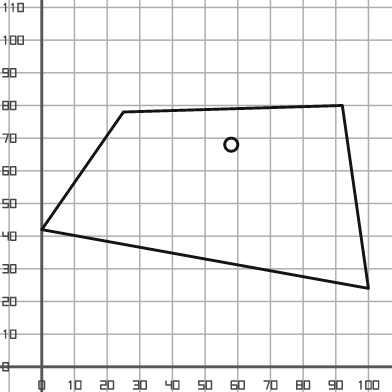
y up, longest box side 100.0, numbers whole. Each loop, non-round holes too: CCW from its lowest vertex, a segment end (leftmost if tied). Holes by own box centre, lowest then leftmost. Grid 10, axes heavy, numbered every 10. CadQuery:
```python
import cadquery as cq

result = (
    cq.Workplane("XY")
    .moveTo(100.0, 24.0)
    .lineTo(92.0, 80.0)
    .lineTo(25.0, 78.0)
    .lineTo(0.0, 42.0)
    .close()
    .moveTo(58.0, 68.0)
    .circle(2.0)
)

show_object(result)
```